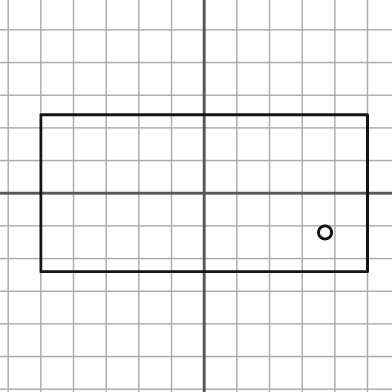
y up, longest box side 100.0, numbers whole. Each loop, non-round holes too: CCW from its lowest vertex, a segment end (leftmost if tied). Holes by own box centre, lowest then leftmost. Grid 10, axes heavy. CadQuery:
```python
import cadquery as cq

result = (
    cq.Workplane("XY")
    .moveTo(-50.0, -24.0)
    .lineTo(50.0, -24.0)
    .lineTo(50.0, 24.0)
    .lineTo(-50.0, 24.0)
    .close()
    .moveTo(37.0, -12.0)
    .circle(2.0)
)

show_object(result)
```